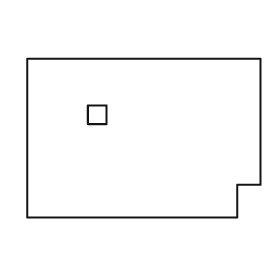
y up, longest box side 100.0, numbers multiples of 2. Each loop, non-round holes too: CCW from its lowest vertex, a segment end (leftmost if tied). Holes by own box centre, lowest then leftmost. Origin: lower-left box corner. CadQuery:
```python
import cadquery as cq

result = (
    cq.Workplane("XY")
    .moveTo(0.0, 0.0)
    .lineTo(90.0, 0.0)
    .lineTo(90.0, 14.0)
    .lineTo(100.0, 14.0)
    .lineTo(100.0, 68.0)
    .lineTo(0.0, 68.0)
    .close()
    .moveTo(26.0, 40.0)
    .lineTo(34.0, 40.0)
    .lineTo(34.0, 48.0)
    .lineTo(26.0, 48.0)
    .close()
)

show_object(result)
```